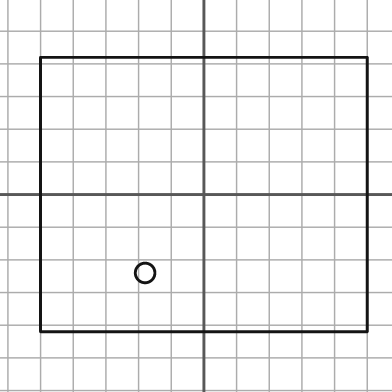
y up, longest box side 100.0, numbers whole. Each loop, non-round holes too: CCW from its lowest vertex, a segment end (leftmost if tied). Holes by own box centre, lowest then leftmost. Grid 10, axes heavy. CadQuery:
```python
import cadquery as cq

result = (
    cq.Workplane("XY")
    .moveTo(-50.0, -42.0)
    .lineTo(50.0, -42.0)
    .lineTo(50.0, 42.0)
    .lineTo(-50.0, 42.0)
    .close()
    .moveTo(-18.0, -24.0)
    .circle(3.0)
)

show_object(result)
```